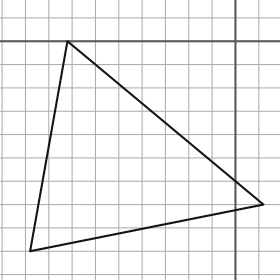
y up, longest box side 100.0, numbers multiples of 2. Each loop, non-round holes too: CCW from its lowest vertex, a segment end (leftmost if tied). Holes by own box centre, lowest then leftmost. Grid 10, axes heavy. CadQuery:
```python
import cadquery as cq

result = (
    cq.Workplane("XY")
    .moveTo(-88.0, -90.0)
    .lineTo(12.0, -70.0)
    .lineTo(-72.0, 0.0)
    .close()
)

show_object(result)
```